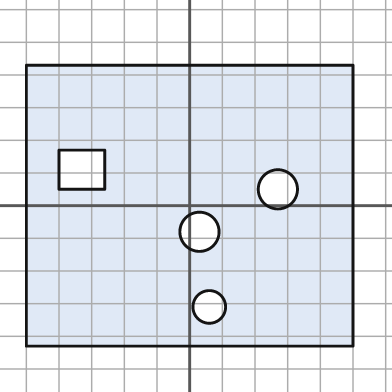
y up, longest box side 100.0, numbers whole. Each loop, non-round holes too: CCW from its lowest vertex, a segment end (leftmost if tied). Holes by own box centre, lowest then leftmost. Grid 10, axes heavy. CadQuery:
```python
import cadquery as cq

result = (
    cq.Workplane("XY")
    .moveTo(-50.0, -43.0)
    .lineTo(50.0, -43.0)
    .lineTo(50.0, 43.0)
    .lineTo(-50.0, 43.0)
    .close()
    .moveTo(6.0, -31.0)
    .circle(5.0)
    .moveTo(3.0, -8.0)
    .circle(6.0)
    .moveTo(27.0, 5.0)
    .circle(6.0)
    .moveTo(-40.0, 5.0)
    .lineTo(-26.0, 5.0)
    .lineTo(-26.0, 17.0)
    .lineTo(-40.0, 17.0)
    .close()
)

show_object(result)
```